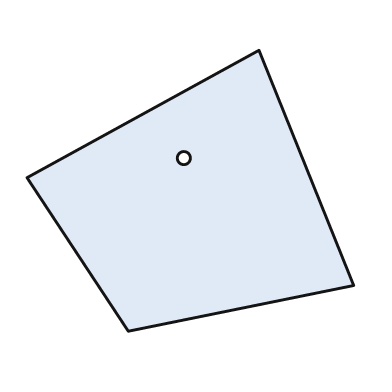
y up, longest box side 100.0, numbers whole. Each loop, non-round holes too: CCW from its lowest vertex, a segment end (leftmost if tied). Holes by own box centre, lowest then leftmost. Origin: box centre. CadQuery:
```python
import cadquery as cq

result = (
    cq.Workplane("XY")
    .moveTo(-19.0, -43.0)
    .lineTo(50.0, -29.0)
    .lineTo(21.0, 43.0)
    .lineTo(-50.0, 4.0)
    .close()
    .moveTo(-2.0, 10.0)
    .circle(2.0)
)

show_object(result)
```